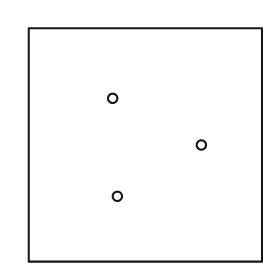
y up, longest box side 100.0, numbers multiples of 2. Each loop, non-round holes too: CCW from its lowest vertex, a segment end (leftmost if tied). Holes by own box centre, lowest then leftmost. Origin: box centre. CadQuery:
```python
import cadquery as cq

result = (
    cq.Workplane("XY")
    .moveTo(-50.0, -50.0)
    .lineTo(50.0, -50.0)
    .lineTo(50.0, 50.0)
    .lineTo(-50.0, 50.0)
    .close()
    .moveTo(-12.0, -22.0)
    .circle(2.0)
    .moveTo(24.0, 0.0)
    .circle(2.0)
    .moveTo(-14.0, 20.0)
    .circle(2.0)
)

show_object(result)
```